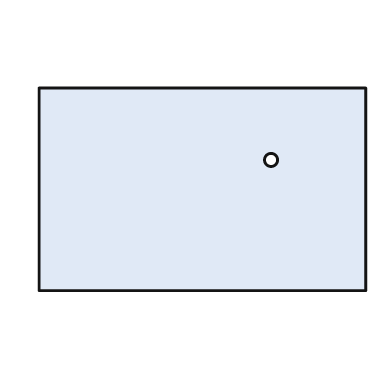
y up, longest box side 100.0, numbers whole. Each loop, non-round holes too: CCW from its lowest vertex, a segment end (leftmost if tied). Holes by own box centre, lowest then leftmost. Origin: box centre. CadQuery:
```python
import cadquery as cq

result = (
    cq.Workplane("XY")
    .moveTo(-50.0, -31.0)
    .lineTo(50.0, -31.0)
    .lineTo(50.0, 31.0)
    .lineTo(-50.0, 31.0)
    .close()
    .moveTo(21.0, 9.0)
    .circle(2.0)
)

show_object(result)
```